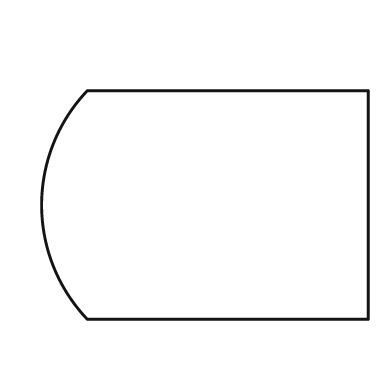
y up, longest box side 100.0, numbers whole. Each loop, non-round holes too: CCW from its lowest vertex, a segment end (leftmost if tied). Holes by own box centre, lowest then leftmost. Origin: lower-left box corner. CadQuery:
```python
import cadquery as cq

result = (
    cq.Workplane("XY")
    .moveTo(14.0, 0.0)
    .lineTo(100.0, 0.0)
    .lineTo(100.0, 70.0)
    .lineTo(14.0, 70.0)
    .threePointArc((0.0, 35.0), (14.0, 0.0))
    .close()
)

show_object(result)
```